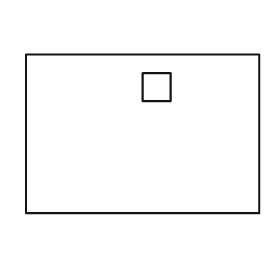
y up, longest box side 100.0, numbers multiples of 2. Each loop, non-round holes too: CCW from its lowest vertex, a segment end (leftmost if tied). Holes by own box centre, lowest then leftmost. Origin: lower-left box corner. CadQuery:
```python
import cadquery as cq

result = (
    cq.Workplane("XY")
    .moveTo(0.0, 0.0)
    .lineTo(100.0, 0.0)
    .lineTo(100.0, 68.0)
    .lineTo(0.0, 68.0)
    .close()
    .moveTo(50.0, 48.0)
    .lineTo(62.0, 48.0)
    .lineTo(62.0, 60.0)
    .lineTo(50.0, 60.0)
    .close()
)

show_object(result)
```